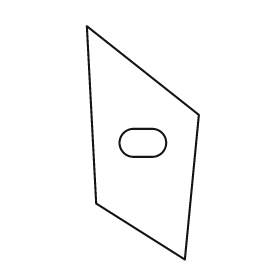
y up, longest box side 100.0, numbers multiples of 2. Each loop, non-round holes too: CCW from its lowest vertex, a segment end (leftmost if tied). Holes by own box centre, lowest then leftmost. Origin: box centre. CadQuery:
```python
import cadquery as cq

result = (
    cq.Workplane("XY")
    .moveTo(18.0, -50.0)
    .lineTo(24.0, 12.0)
    .lineTo(-24.0, 50.0)
    .lineTo(-20.0, -26.0)
    .close()
    .moveTo(-4.0, -6.0)
    .lineTo(4.0, -6.0)
    .threePointArc((10.0, 0.0), (4.0, 6.0))
    .lineTo(-4.0, 6.0)
    .threePointArc((-10.0, 0.0), (-4.0, -6.0))
    .close()
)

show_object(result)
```